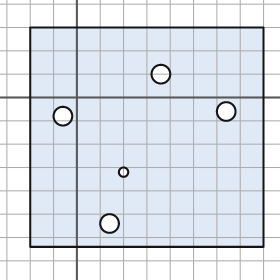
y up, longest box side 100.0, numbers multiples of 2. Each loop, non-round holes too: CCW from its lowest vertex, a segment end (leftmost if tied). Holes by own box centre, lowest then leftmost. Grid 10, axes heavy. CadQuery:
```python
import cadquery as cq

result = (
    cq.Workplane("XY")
    .moveTo(-20.0, -64.0)
    .lineTo(80.0, -64.0)
    .lineTo(80.0, 30.0)
    .lineTo(-20.0, 30.0)
    .close()
    .moveTo(14.0, -54.0)
    .circle(4.0)
    .moveTo(20.0, -32.0)
    .circle(2.0)
    .moveTo(-6.0, -8.0)
    .circle(4.0)
    .moveTo(64.0, -6.0)
    .circle(4.0)
    .moveTo(36.0, 10.0)
    .circle(4.0)
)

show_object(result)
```